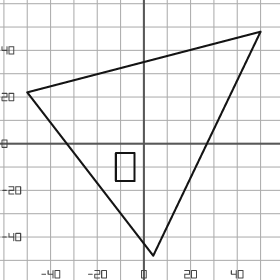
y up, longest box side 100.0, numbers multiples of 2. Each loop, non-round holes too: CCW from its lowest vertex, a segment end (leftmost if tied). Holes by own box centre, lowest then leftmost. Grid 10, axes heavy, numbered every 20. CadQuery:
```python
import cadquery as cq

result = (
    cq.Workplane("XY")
    .moveTo(4.0, -48.0)
    .lineTo(50.0, 48.0)
    .lineTo(-50.0, 22.0)
    .close()
    .moveTo(-12.0, -16.0)
    .lineTo(-4.0, -16.0)
    .lineTo(-4.0, -4.0)
    .lineTo(-12.0, -4.0)
    .close()
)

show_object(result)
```